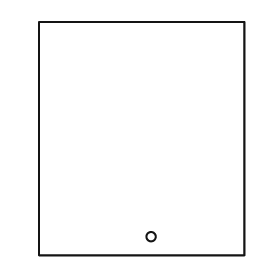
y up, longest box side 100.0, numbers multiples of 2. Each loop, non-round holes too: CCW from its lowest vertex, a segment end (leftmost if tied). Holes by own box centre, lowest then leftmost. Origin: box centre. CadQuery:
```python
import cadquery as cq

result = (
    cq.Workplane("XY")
    .moveTo(-44.0, -50.0)
    .lineTo(44.0, -50.0)
    .lineTo(44.0, 50.0)
    .lineTo(-44.0, 50.0)
    .close()
    .moveTo(4.0, -42.0)
    .circle(2.0)
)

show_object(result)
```